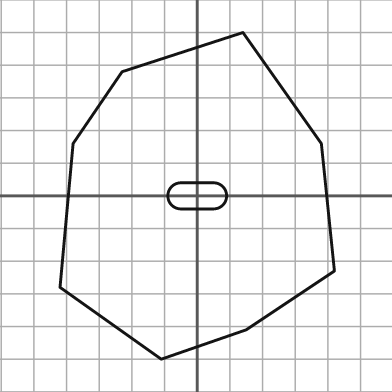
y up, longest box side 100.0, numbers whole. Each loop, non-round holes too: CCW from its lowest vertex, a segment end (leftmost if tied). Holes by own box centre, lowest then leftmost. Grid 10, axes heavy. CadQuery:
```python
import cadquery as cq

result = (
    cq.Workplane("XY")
    .moveTo(-11.0, -50.0)
    .lineTo(15.0, -41.0)
    .lineTo(42.0, -23.0)
    .lineTo(38.0, 16.0)
    .lineTo(14.0, 50.0)
    .lineTo(-23.0, 38.0)
    .lineTo(-38.0, 16.0)
    .lineTo(-42.0, -28.0)
    .close()
    .moveTo(-5.0, -4.0)
    .lineTo(5.0, -4.0)
    .threePointArc((9.0, 0.0), (5.0, 4.0))
    .lineTo(-5.0, 4.0)
    .threePointArc((-9.0, 0.0), (-5.0, -4.0))
    .close()
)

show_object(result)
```